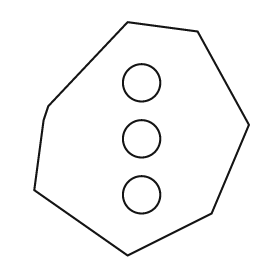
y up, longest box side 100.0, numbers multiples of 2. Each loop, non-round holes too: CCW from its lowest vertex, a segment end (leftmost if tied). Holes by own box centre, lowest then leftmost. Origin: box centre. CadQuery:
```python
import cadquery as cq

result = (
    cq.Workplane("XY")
    .moveTo(-6.0, -50.0)
    .lineTo(30.0, -32.0)
    .lineTo(46.0, 6.0)
    .lineTo(24.0, 46.0)
    .lineTo(-6.0, 50.0)
    .lineTo(-40.0, 14.0)
    .lineTo(-42.0, 8.0)
    .lineTo(-46.0, -22.0)
    .close()
    .moveTo(0.0, -24.0)
    .circle(8.0)
    .moveTo(0.0, 0.0)
    .circle(8.0)
    .moveTo(0.0, 24.0)
    .circle(8.0)
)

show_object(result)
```